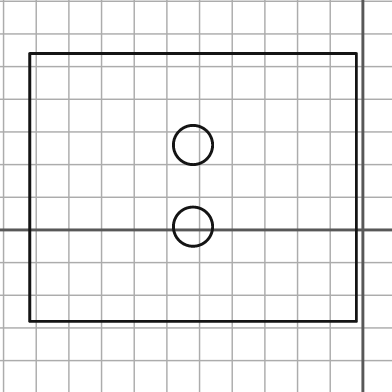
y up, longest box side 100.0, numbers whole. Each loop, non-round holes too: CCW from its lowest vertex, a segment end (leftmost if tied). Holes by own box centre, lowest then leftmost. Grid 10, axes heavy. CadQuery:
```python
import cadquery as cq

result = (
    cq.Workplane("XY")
    .moveTo(-102.0, -28.0)
    .lineTo(-2.0, -28.0)
    .lineTo(-2.0, 54.0)
    .lineTo(-102.0, 54.0)
    .close()
    .moveTo(-52.0, 1.0)
    .circle(6.0)
    .moveTo(-52.0, 26.0)
    .circle(6.0)
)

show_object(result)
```